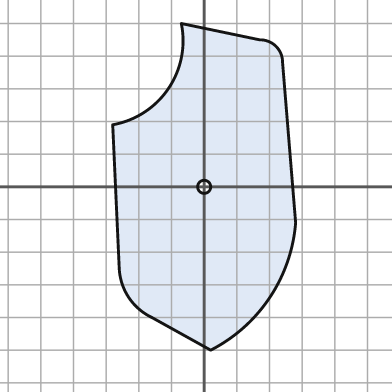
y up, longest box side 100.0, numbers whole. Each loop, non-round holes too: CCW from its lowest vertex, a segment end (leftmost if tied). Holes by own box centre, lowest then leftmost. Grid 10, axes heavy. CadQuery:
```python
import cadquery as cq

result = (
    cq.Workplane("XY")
    .moveTo(2.0, -50.0)
    .threePointArc((20.0, -34.0), (28.0, -11.0))
    .lineTo(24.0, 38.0)
    .threePointArc((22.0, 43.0), (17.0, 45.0))
    .lineTo(-7.0, 50.0)
    .threePointArc((-11.0, 30.0), (-28.0, 19.0))
    .lineTo(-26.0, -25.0)
    .threePointArc((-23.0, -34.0), (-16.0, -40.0))
    .close()
    .moveTo(0.0, 0.0)
    .circle(2.0)
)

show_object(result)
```